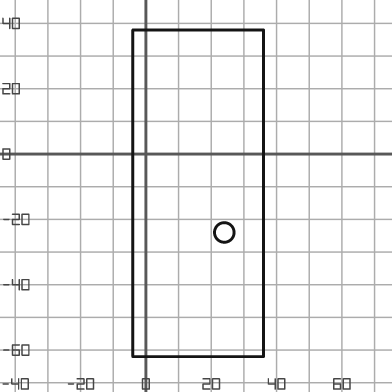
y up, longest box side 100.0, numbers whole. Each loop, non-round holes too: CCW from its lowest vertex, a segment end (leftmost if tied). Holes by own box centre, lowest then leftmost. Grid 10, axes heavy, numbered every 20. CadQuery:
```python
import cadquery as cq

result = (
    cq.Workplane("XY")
    .moveTo(-4.0, -62.0)
    .lineTo(36.0, -62.0)
    .lineTo(36.0, 38.0)
    .lineTo(-4.0, 38.0)
    .close()
    .moveTo(24.0, -24.0)
    .circle(3.0)
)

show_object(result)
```